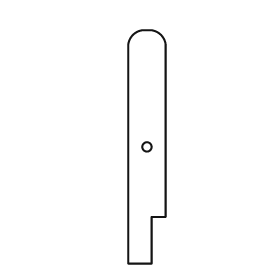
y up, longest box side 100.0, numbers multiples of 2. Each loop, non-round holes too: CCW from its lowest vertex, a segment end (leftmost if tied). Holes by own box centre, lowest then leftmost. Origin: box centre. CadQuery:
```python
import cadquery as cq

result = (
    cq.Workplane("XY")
    .moveTo(-8.0, -50.0)
    .lineTo(2.0, -50.0)
    .lineTo(2.0, -30.0)
    .lineTo(8.0, -30.0)
    .lineTo(8.0, 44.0)
    .threePointArc((6.0, 48.0), (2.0, 50.0))
    .lineTo(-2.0, 50.0)
    .threePointArc((-6.0, 48.0), (-8.0, 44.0))
    .close()
    .moveTo(0.0, 0.0)
    .circle(2.0)
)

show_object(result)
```